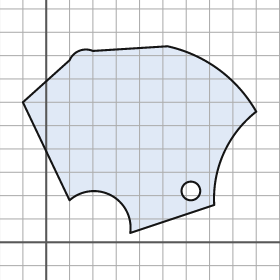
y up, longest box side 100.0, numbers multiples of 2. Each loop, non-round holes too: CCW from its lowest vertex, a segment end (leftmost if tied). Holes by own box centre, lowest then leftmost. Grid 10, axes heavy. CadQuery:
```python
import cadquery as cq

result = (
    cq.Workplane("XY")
    .moveTo(36.0, 4.0)
    .lineTo(72.0, 16.0)
    .threePointArc((76.0, 38.0), (90.0, 56.0))
    .threePointArc((74.0, 74.0), (52.0, 84.0))
    .lineTo(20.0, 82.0)
    .threePointArc((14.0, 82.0), (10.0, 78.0))
    .lineTo(-10.0, 60.0)
    .lineTo(10.0, 18.0)
    .threePointArc((28.0, 20.0), (36.0, 4.0))
    .close()
    .moveTo(62.0, 22.0)
    .circle(4.0)
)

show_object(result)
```